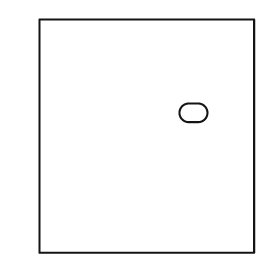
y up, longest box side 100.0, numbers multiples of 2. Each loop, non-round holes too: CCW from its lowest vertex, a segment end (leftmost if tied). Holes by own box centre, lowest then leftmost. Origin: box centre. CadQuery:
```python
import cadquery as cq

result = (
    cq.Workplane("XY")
    .moveTo(-46.0, -50.0)
    .lineTo(46.0, -50.0)
    .lineTo(46.0, 50.0)
    .lineTo(-46.0, 50.0)
    .close()
    .moveTo(18.0, 6.0)
    .lineTo(22.0, 6.0)
    .threePointArc((26.0, 10.0), (22.0, 14.0))
    .lineTo(18.0, 14.0)
    .threePointArc((14.0, 10.0), (18.0, 6.0))
    .close()
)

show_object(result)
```